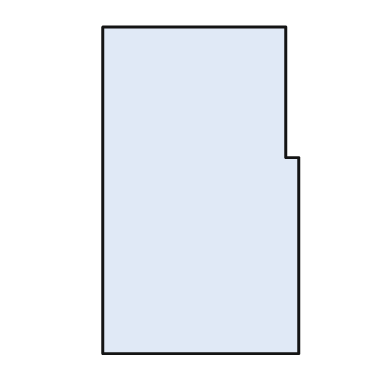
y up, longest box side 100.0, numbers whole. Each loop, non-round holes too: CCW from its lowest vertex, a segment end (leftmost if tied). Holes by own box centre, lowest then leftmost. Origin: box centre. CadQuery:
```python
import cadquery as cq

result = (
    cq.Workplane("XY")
    .moveTo(-30.0, -50.0)
    .lineTo(30.0, -50.0)
    .lineTo(30.0, 10.0)
    .lineTo(26.0, 10.0)
    .lineTo(26.0, 50.0)
    .lineTo(-30.0, 50.0)
    .close()
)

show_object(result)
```